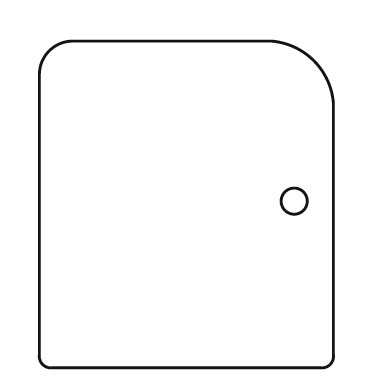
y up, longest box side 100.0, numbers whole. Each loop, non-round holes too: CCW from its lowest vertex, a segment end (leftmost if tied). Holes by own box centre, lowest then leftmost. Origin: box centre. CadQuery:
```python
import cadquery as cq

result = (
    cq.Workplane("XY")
    .moveTo(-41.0, -50.0)
    .lineTo(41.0, -50.0)
    .threePointArc((44.0, -49.0), (45.0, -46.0))
    .lineTo(45.0, 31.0)
    .threePointArc((39.0, 44.0), (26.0, 50.0))
    .lineTo(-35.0, 50.0)
    .threePointArc((-42.0, 47.0), (-45.0, 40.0))
    .lineTo(-45.0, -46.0)
    .threePointArc((-44.0, -49.0), (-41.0, -50.0))
    .close()
    .moveTo(33.0, 1.0)
    .circle(4.0)
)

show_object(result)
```